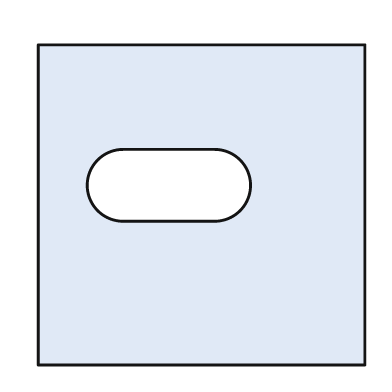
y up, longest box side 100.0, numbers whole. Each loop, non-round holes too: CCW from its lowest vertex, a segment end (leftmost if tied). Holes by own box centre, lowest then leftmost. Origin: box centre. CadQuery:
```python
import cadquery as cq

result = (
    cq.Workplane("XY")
    .moveTo(-50.0, -49.0)
    .lineTo(50.0, -49.0)
    .lineTo(50.0, 49.0)
    .lineTo(-50.0, 49.0)
    .close()
    .moveTo(-24.0, -5.0)
    .lineTo(4.0, -5.0)
    .threePointArc((15.0, 6.0), (4.0, 17.0))
    .lineTo(-24.0, 17.0)
    .threePointArc((-35.0, 6.0), (-24.0, -5.0))
    .close()
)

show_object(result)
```